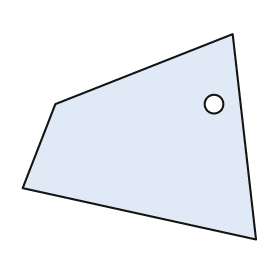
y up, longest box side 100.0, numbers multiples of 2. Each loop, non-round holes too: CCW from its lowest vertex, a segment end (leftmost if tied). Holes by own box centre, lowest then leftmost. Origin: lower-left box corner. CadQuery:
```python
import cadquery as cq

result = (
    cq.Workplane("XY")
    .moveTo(100.0, 0.0)
    .lineTo(90.0, 88.0)
    .lineTo(14.0, 58.0)
    .lineTo(0.0, 22.0)
    .close()
    .moveTo(82.0, 58.0)
    .circle(4.0)
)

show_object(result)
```